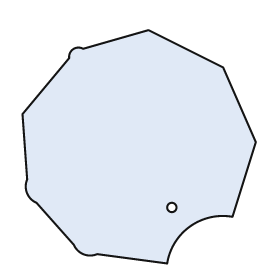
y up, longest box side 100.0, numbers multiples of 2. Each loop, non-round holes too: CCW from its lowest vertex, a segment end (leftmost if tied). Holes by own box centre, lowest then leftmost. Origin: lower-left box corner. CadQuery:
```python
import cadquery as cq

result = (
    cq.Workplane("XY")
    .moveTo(62.0, 0.0)
    .threePointArc((72.0, 16.0), (90.0, 20.0))
    .lineTo(100.0, 52.0)
    .lineTo(86.0, 84.0)
    .lineTo(54.0, 100.0)
    .lineTo(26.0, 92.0)
    .threePointArc((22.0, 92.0), (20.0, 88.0))
    .lineTo(0.0, 64.0)
    .lineTo(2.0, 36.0)
    .threePointArc((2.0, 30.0), (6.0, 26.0))
    .lineTo(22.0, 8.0)
    .threePointArc((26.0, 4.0), (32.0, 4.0))
    .close()
    .moveTo(64.0, 24.0)
    .circle(2.0)
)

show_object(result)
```